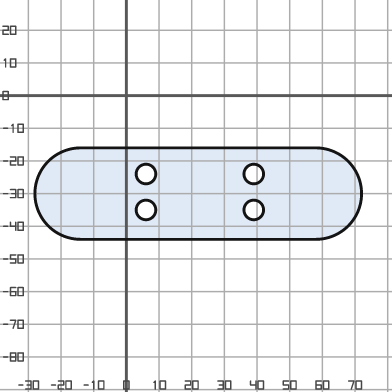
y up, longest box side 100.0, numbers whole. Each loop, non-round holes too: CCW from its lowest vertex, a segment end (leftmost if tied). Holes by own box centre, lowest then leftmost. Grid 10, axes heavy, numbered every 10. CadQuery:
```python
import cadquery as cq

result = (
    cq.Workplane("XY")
    .moveTo(-14.0, -44.0)
    .lineTo(58.0, -44.0)
    .threePointArc((72.0, -30.0), (58.0, -16.0))
    .lineTo(-14.0, -16.0)
    .threePointArc((-28.0, -30.0), (-14.0, -44.0))
    .close()
    .moveTo(6.0, -35.0)
    .circle(3.0)
    .moveTo(39.0, -35.0)
    .circle(3.0)
    .moveTo(6.0, -24.0)
    .circle(3.0)
    .moveTo(39.0, -24.0)
    .circle(3.0)
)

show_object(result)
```